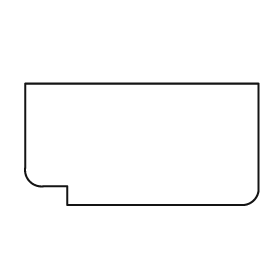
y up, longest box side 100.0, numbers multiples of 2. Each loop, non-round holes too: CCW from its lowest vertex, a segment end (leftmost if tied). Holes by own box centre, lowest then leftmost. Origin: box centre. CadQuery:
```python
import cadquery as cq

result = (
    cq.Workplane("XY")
    .moveTo(-32.0, -26.0)
    .lineTo(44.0, -26.0)
    .threePointArc((48.0, -24.0), (50.0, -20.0))
    .lineTo(50.0, 26.0)
    .lineTo(-50.0, 26.0)
    .lineTo(-50.0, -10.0)
    .threePointArc((-48.0, -16.0), (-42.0, -18.0))
    .lineTo(-32.0, -18.0)
    .close()
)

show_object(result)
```